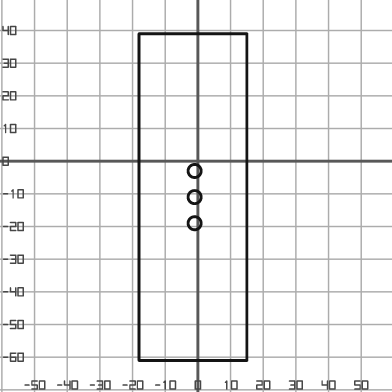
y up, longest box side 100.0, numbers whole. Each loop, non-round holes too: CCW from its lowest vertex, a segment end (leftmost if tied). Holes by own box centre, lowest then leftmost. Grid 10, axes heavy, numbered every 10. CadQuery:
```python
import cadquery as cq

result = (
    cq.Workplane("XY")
    .moveTo(-18.0, -61.0)
    .lineTo(15.0, -61.0)
    .lineTo(15.0, 39.0)
    .lineTo(-18.0, 39.0)
    .close()
    .moveTo(-1.0, -19.0)
    .circle(2.0)
    .moveTo(-1.0, -11.0)
    .circle(2.0)
    .moveTo(-1.0, -3.0)
    .circle(2.0)
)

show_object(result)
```